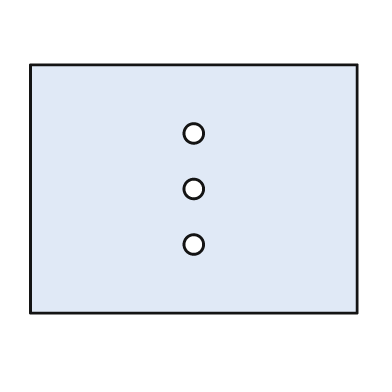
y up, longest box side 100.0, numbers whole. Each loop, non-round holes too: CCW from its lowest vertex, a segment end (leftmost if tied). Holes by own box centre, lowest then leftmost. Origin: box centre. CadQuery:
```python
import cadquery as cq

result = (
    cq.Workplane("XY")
    .moveTo(-50.0, -38.0)
    .lineTo(50.0, -38.0)
    .lineTo(50.0, 38.0)
    .lineTo(-50.0, 38.0)
    .close()
    .moveTo(0.0, -17.0)
    .circle(3.0)
    .moveTo(0.0, 0.0)
    .circle(3.0)
    .moveTo(0.0, 17.0)
    .circle(3.0)
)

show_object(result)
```